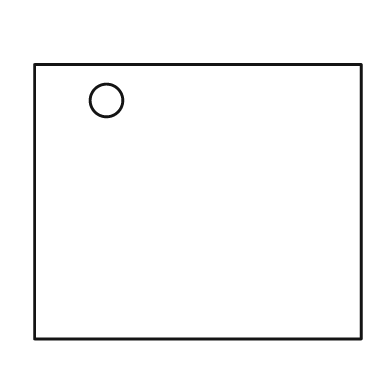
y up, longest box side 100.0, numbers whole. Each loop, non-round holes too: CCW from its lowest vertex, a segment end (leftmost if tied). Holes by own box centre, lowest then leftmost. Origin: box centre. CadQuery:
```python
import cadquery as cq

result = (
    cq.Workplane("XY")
    .moveTo(-50.0, -42.0)
    .lineTo(50.0, -42.0)
    .lineTo(50.0, 42.0)
    .lineTo(-50.0, 42.0)
    .close()
    .moveTo(-28.0, 31.0)
    .circle(5.0)
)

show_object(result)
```